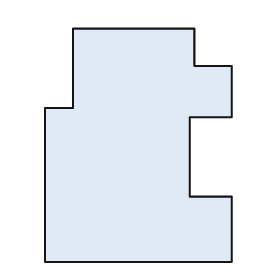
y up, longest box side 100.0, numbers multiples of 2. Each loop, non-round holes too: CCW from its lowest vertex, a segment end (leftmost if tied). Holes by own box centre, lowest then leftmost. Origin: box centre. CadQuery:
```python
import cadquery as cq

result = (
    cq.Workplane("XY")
    .moveTo(-40.0, -50.0)
    .lineTo(40.0, -50.0)
    .lineTo(40.0, -22.0)
    .lineTo(22.0, -22.0)
    .lineTo(22.0, 12.0)
    .lineTo(40.0, 12.0)
    .lineTo(40.0, 34.0)
    .lineTo(24.0, 34.0)
    .lineTo(24.0, 50.0)
    .lineTo(-28.0, 50.0)
    .lineTo(-28.0, 16.0)
    .lineTo(-40.0, 16.0)
    .close()
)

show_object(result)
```